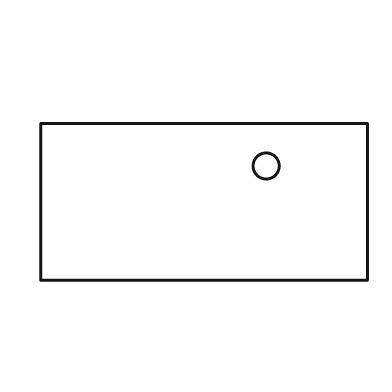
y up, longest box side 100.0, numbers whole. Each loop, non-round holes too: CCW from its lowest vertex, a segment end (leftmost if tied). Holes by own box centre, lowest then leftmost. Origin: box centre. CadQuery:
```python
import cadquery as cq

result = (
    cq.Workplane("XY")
    .moveTo(-50.0, -24.0)
    .lineTo(50.0, -24.0)
    .lineTo(50.0, 24.0)
    .lineTo(-50.0, 24.0)
    .close()
    .moveTo(19.0, 11.0)
    .circle(4.0)
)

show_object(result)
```